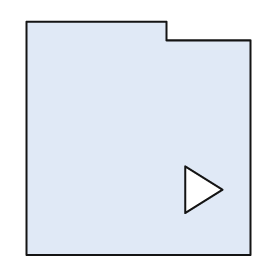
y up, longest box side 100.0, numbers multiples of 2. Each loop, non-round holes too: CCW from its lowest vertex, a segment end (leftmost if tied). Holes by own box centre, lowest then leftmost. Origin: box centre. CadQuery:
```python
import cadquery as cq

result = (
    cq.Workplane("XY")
    .moveTo(-48.0, -50.0)
    .lineTo(48.0, -50.0)
    .lineTo(48.0, 42.0)
    .lineTo(12.0, 42.0)
    .lineTo(12.0, 50.0)
    .lineTo(-48.0, 50.0)
    .close()
    .moveTo(20.0, -32.0)
    .lineTo(36.0, -22.0)
    .lineTo(20.0, -12.0)
    .close()
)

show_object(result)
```